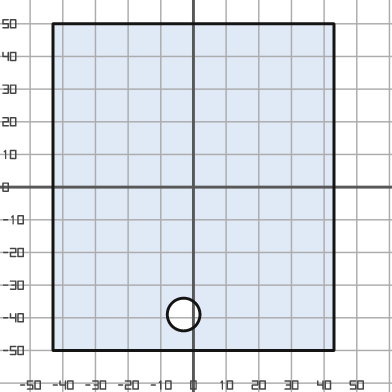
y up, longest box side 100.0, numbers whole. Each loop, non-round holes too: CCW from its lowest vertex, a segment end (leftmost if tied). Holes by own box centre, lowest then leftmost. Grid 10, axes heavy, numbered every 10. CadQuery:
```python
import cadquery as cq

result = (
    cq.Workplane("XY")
    .moveTo(-43.0, -50.0)
    .lineTo(43.0, -50.0)
    .lineTo(43.0, 50.0)
    .lineTo(-43.0, 50.0)
    .close()
    .moveTo(-3.0, -39.0)
    .circle(5.0)
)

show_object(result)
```